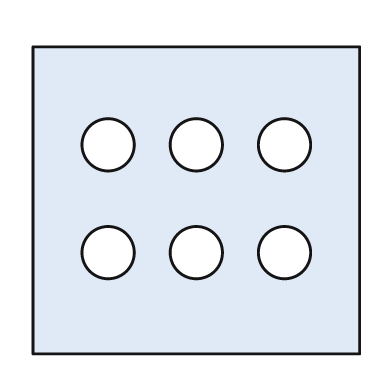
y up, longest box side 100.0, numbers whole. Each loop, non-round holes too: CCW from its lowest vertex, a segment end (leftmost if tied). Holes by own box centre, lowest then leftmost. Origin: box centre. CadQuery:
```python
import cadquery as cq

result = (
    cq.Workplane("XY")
    .moveTo(-50.0, -47.0)
    .lineTo(50.0, -47.0)
    .lineTo(50.0, 47.0)
    .lineTo(-50.0, 47.0)
    .close()
    .moveTo(-27.0, -16.0)
    .circle(8.0)
    .moveTo(0.0, -16.0)
    .circle(8.0)
    .moveTo(27.0, -16.0)
    .circle(8.0)
    .moveTo(-27.0, 17.0)
    .circle(8.0)
    .moveTo(0.0, 17.0)
    .circle(8.0)
    .moveTo(27.0, 17.0)
    .circle(8.0)
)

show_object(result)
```